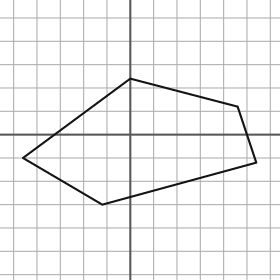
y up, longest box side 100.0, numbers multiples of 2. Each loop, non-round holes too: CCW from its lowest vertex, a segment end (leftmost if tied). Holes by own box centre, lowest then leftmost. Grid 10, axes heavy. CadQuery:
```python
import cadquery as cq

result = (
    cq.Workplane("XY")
    .moveTo(-12.0, -30.0)
    .lineTo(54.0, -12.0)
    .lineTo(46.0, 12.0)
    .lineTo(0.0, 24.0)
    .lineTo(-46.0, -10.0)
    .close()
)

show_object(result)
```